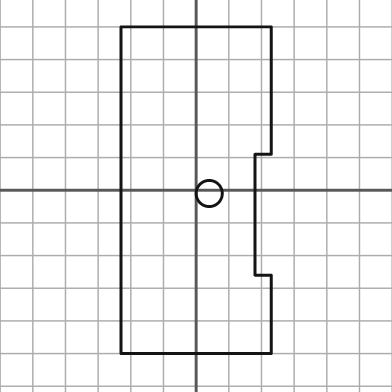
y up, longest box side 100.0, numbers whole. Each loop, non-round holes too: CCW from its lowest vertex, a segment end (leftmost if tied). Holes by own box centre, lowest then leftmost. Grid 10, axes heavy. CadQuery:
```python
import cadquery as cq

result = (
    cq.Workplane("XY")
    .moveTo(-23.0, -50.0)
    .lineTo(23.0, -50.0)
    .lineTo(23.0, -26.0)
    .lineTo(18.0, -26.0)
    .lineTo(18.0, 11.0)
    .lineTo(23.0, 11.0)
    .lineTo(23.0, 50.0)
    .lineTo(-23.0, 50.0)
    .close()
    .moveTo(4.0, -1.0)
    .circle(4.0)
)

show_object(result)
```